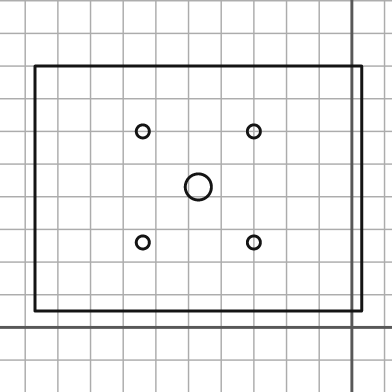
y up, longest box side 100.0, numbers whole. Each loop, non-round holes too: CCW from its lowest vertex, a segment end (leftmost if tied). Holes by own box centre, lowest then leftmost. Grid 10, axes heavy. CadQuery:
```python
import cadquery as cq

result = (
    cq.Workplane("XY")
    .moveTo(-97.0, 5.0)
    .lineTo(3.0, 5.0)
    .lineTo(3.0, 80.0)
    .lineTo(-97.0, 80.0)
    .close()
    .moveTo(-64.0, 26.0)
    .circle(2.0)
    .moveTo(-30.0, 26.0)
    .circle(2.0)
    .moveTo(-47.0, 43.0)
    .circle(4.0)
    .moveTo(-64.0, 60.0)
    .circle(2.0)
    .moveTo(-30.0, 60.0)
    .circle(2.0)
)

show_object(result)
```